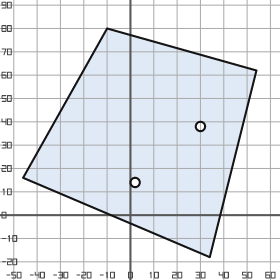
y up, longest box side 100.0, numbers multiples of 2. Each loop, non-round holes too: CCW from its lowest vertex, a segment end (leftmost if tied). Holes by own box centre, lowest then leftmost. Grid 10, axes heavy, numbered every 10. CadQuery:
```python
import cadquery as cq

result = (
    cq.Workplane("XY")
    .moveTo(34.0, -18.0)
    .lineTo(54.0, 62.0)
    .lineTo(-10.0, 80.0)
    .lineTo(-46.0, 16.0)
    .close()
    .moveTo(2.0, 14.0)
    .circle(2.0)
    .moveTo(30.0, 38.0)
    .circle(2.0)
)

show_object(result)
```